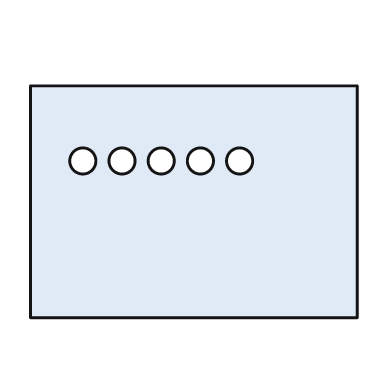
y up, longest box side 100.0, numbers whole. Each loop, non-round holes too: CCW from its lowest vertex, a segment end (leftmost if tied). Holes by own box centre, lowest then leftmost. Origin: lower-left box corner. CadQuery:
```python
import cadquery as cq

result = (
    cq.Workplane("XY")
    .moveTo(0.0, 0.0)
    .lineTo(100.0, 0.0)
    .lineTo(100.0, 71.0)
    .lineTo(0.0, 71.0)
    .close()
    .moveTo(16.0, 48.0)
    .circle(4.0)
    .moveTo(28.0, 48.0)
    .circle(4.0)
    .moveTo(40.0, 48.0)
    .circle(4.0)
    .moveTo(52.0, 48.0)
    .circle(4.0)
    .moveTo(64.0, 48.0)
    .circle(4.0)
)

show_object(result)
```